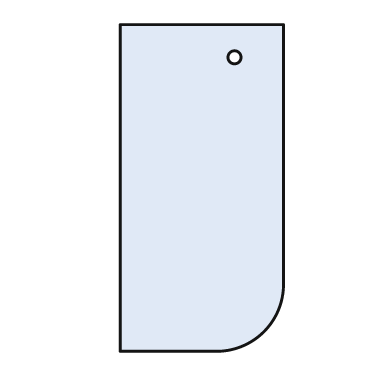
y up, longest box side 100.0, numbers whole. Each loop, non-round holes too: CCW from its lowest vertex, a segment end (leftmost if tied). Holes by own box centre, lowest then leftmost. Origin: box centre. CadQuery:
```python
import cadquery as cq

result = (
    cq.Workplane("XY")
    .moveTo(-25.0, -50.0)
    .lineTo(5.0, -50.0)
    .threePointArc((19.0, -44.0), (25.0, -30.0))
    .lineTo(25.0, 50.0)
    .lineTo(-25.0, 50.0)
    .close()
    .moveTo(10.0, 40.0)
    .circle(2.0)
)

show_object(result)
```